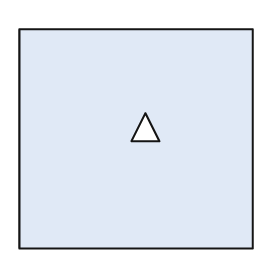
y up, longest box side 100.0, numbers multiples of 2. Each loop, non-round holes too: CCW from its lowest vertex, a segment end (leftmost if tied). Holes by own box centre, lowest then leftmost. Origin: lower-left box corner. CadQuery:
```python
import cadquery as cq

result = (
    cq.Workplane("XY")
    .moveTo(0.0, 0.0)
    .lineTo(100.0, 0.0)
    .lineTo(100.0, 94.0)
    .lineTo(0.0, 94.0)
    .close()
    .moveTo(48.0, 46.0)
    .lineTo(60.0, 46.0)
    .lineTo(54.0, 58.0)
    .close()
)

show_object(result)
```